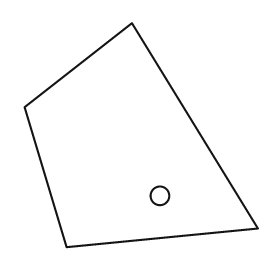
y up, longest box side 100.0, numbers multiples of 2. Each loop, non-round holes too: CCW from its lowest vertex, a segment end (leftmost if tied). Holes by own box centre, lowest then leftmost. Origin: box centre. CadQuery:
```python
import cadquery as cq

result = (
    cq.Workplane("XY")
    .moveTo(-32.0, -48.0)
    .lineTo(50.0, -40.0)
    .lineTo(-4.0, 48.0)
    .lineTo(-50.0, 12.0)
    .close()
    .moveTo(8.0, -26.0)
    .circle(4.0)
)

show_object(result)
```